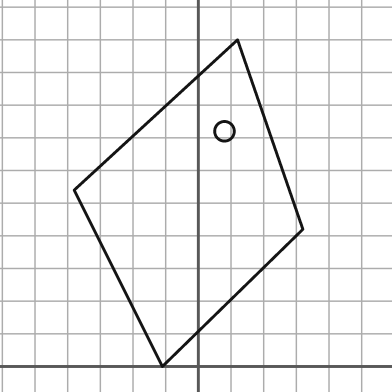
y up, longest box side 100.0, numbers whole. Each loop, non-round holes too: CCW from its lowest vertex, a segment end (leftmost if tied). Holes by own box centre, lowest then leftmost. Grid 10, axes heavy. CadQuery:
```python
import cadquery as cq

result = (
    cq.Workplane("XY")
    .moveTo(-11.0, 0.0)
    .lineTo(32.0, 42.0)
    .lineTo(12.0, 100.0)
    .lineTo(-38.0, 54.0)
    .close()
    .moveTo(8.0, 72.0)
    .circle(3.0)
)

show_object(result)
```